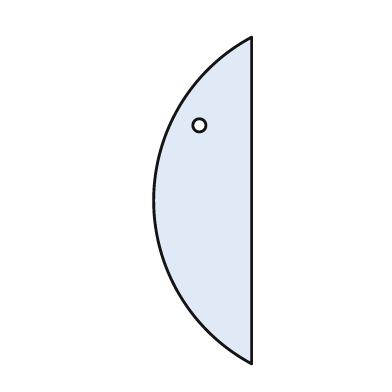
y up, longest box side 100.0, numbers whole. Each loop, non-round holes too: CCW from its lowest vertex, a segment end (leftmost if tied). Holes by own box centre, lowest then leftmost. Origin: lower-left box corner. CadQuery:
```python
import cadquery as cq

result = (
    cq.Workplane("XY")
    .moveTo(30.0, 0.0)
    .lineTo(30.0, 100.0)
    .threePointArc((0.0, 50.0), (30.0, 0.0))
    .close()
    .moveTo(14.0, 73.0)
    .circle(2.0)
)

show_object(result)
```